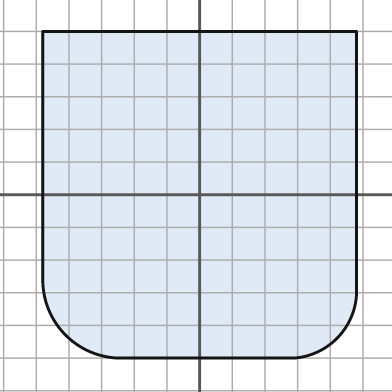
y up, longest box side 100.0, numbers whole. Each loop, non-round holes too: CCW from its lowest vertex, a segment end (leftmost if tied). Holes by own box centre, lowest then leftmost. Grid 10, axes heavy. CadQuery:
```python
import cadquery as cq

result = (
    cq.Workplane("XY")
    .moveTo(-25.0, -50.0)
    .lineTo(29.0, -50.0)
    .threePointArc((42.0, -44.0), (48.0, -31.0))
    .lineTo(48.0, 50.0)
    .lineTo(-48.0, 50.0)
    .lineTo(-48.0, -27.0)
    .threePointArc((-41.0, -43.0), (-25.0, -50.0))
    .close()
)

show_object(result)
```